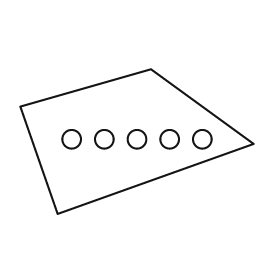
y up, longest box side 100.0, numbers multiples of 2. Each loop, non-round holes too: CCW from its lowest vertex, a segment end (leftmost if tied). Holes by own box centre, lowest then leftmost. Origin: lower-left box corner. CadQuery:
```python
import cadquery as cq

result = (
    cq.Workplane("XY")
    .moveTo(16.0, 0.0)
    .lineTo(100.0, 30.0)
    .lineTo(56.0, 62.0)
    .lineTo(0.0, 46.0)
    .close()
    .moveTo(22.0, 32.0)
    .circle(4.0)
    .moveTo(36.0, 32.0)
    .circle(4.0)
    .moveTo(50.0, 32.0)
    .circle(4.0)
    .moveTo(64.0, 32.0)
    .circle(4.0)
    .moveTo(78.0, 32.0)
    .circle(4.0)
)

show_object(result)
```